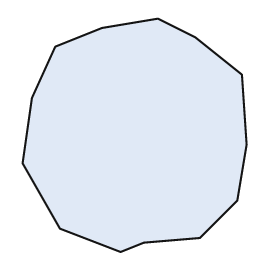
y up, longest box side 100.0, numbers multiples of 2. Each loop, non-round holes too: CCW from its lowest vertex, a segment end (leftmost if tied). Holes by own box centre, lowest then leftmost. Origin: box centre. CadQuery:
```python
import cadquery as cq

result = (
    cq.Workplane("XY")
    .moveTo(-6.0, -50.0)
    .lineTo(4.0, -46.0)
    .lineTo(28.0, -44.0)
    .lineTo(44.0, -28.0)
    .lineTo(48.0, -4.0)
    .lineTo(46.0, 26.0)
    .lineTo(26.0, 42.0)
    .lineTo(10.0, 50.0)
    .lineTo(-14.0, 46.0)
    .lineTo(-34.0, 38.0)
    .lineTo(-44.0, 16.0)
    .lineTo(-48.0, -12.0)
    .lineTo(-32.0, -40.0)
    .close()
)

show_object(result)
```